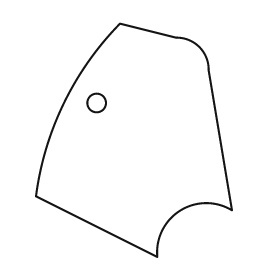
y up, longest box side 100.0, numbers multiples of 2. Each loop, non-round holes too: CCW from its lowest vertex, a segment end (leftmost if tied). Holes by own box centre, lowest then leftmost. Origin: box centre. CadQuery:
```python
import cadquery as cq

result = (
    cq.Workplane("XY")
    .moveTo(10.0, -50.0)
    .threePointArc((20.0, -30.0), (42.0, -30.0))
    .lineTo(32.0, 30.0)
    .threePointArc((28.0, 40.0), (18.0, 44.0))
    .lineTo(-6.0, 50.0)
    .threePointArc((-30.0, 16.0), (-42.0, -24.0))
    .close()
    .moveTo(-16.0, 16.0)
    .circle(4.0)
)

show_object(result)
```